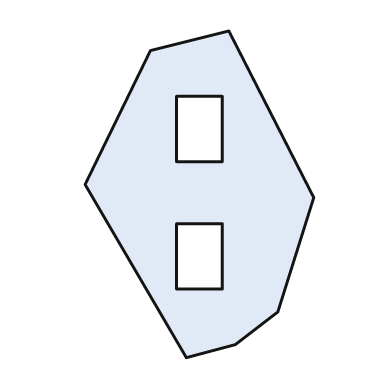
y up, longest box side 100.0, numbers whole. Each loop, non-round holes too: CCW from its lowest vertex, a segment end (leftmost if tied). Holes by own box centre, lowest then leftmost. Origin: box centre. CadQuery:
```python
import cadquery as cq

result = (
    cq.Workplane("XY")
    .moveTo(-4.0, -50.0)
    .lineTo(11.0, -46.0)
    .lineTo(24.0, -36.0)
    .lineTo(35.0, -1.0)
    .lineTo(9.0, 50.0)
    .lineTo(-15.0, 44.0)
    .lineTo(-35.0, 3.0)
    .close()
    .moveTo(-7.0, -29.0)
    .lineTo(7.0, -29.0)
    .lineTo(7.0, -9.0)
    .lineTo(-7.0, -9.0)
    .close()
    .moveTo(-7.0, 10.0)
    .lineTo(7.0, 10.0)
    .lineTo(7.0, 30.0)
    .lineTo(-7.0, 30.0)
    .close()
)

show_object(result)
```